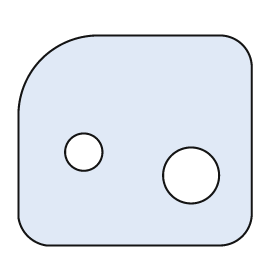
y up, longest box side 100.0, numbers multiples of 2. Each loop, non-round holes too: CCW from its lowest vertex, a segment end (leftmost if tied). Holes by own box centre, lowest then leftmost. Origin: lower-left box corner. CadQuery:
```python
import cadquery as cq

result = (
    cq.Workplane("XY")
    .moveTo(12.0, 0.0)
    .lineTo(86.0, 0.0)
    .threePointArc((96.0, 4.0), (100.0, 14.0))
    .lineTo(100.0, 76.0)
    .threePointArc((96.0, 86.0), (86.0, 90.0))
    .lineTo(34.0, 90.0)
    .threePointArc((10.0, 80.0), (0.0, 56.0))
    .lineTo(0.0, 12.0)
    .threePointArc((4.0, 4.0), (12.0, 0.0))
    .close()
    .moveTo(74.0, 30.0)
    .circle(12.0)
    .moveTo(28.0, 40.0)
    .circle(8.0)
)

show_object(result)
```